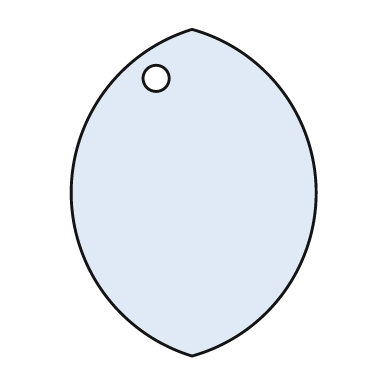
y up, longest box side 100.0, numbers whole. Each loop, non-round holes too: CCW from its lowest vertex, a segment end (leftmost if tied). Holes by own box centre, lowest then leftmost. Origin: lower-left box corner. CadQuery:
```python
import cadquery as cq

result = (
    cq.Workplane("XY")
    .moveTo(37.0, 0.0)
    .threePointArc((75.0, 50.0), (37.0, 100.0))
    .threePointArc((0.0, 50.0), (37.0, 0.0))
    .close()
    .moveTo(26.0, 85.0)
    .circle(4.0)
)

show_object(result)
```